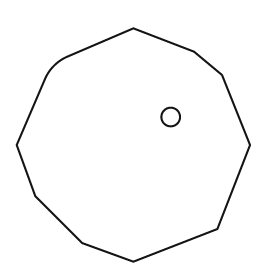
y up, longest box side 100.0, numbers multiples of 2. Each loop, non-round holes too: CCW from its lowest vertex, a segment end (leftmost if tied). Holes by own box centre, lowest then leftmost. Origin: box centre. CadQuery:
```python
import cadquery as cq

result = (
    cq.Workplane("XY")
    .moveTo(0.0, -50.0)
    .lineTo(36.0, -36.0)
    .lineTo(50.0, 0.0)
    .lineTo(38.0, 30.0)
    .lineTo(26.0, 40.0)
    .lineTo(0.0, 50.0)
    .lineTo(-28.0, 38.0)
    .threePointArc((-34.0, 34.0), (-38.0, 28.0))
    .lineTo(-50.0, 0.0)
    .lineTo(-42.0, -22.0)
    .lineTo(-22.0, -42.0)
    .close()
    .moveTo(16.0, 12.0)
    .circle(4.0)
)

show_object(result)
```